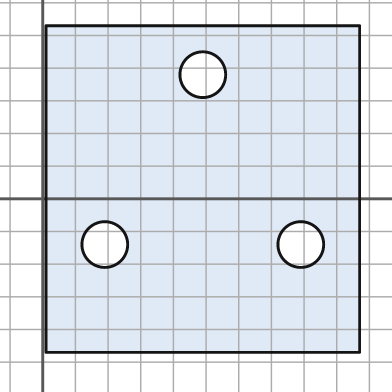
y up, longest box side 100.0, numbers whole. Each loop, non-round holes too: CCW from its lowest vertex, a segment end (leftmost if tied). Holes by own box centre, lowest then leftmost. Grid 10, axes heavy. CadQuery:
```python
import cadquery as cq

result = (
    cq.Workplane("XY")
    .moveTo(1.0, -47.0)
    .lineTo(97.0, -47.0)
    .lineTo(97.0, 53.0)
    .lineTo(1.0, 53.0)
    .close()
    .moveTo(19.0, -14.0)
    .circle(7.0)
    .moveTo(79.0, -14.0)
    .circle(7.0)
    .moveTo(49.0, 38.0)
    .circle(7.0)
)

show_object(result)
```